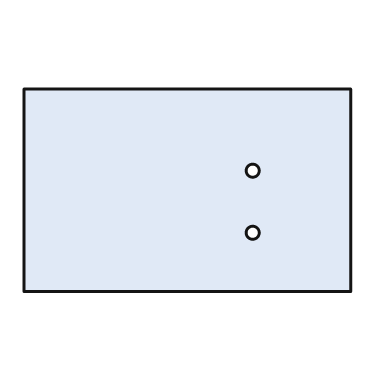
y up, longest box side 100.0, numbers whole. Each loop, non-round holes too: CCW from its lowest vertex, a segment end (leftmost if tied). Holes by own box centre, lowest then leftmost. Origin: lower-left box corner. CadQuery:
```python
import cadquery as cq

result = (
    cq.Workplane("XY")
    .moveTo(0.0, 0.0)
    .lineTo(100.0, 0.0)
    .lineTo(100.0, 62.0)
    .lineTo(0.0, 62.0)
    .close()
    .moveTo(70.0, 18.0)
    .circle(2.0)
    .moveTo(70.0, 37.0)
    .circle(2.0)
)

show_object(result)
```